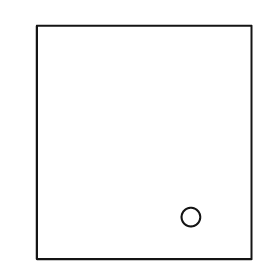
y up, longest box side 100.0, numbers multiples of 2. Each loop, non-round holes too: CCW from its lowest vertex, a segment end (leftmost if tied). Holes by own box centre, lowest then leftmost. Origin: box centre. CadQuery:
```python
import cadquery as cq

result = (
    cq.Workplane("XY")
    .moveTo(-46.0, -50.0)
    .lineTo(46.0, -50.0)
    .lineTo(46.0, 50.0)
    .lineTo(-46.0, 50.0)
    .close()
    .moveTo(20.0, -32.0)
    .circle(4.0)
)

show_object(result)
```